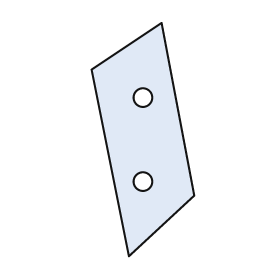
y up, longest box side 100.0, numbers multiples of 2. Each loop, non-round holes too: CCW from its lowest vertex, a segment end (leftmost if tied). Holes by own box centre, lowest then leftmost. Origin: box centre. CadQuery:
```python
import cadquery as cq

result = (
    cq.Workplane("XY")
    .moveTo(-6.0, -50.0)
    .lineTo(22.0, -24.0)
    .lineTo(8.0, 50.0)
    .lineTo(-22.0, 30.0)
    .close()
    .moveTo(0.0, -18.0)
    .circle(4.0)
    .moveTo(0.0, 18.0)
    .circle(4.0)
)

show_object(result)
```